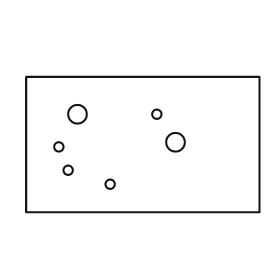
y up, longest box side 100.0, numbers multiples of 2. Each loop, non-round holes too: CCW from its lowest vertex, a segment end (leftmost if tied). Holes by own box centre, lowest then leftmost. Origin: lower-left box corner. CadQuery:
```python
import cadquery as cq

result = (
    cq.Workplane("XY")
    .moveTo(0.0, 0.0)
    .lineTo(100.0, 0.0)
    .lineTo(100.0, 58.0)
    .lineTo(0.0, 58.0)
    .close()
    .moveTo(36.0, 12.0)
    .circle(2.0)
    .moveTo(18.0, 18.0)
    .circle(2.0)
    .moveTo(14.0, 28.0)
    .circle(2.0)
    .moveTo(64.0, 30.0)
    .circle(4.0)
    .moveTo(22.0, 42.0)
    .circle(4.0)
    .moveTo(56.0, 42.0)
    .circle(2.0)
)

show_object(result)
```